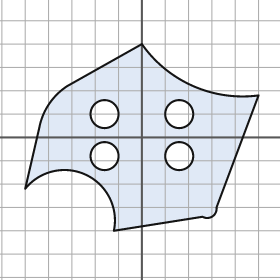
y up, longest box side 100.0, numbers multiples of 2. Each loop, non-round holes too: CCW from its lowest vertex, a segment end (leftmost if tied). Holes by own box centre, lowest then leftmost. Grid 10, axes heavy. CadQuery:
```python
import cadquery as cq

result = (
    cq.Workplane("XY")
    .moveTo(-12.0, -40.0)
    .lineTo(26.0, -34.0)
    .threePointArc((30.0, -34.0), (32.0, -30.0))
    .lineTo(50.0, 18.0)
    .threePointArc((22.0, 22.0), (0.0, 40.0))
    .lineTo(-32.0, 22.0)
    .threePointArc((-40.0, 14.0), (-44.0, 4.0))
    .lineTo(-50.0, -22.0)
    .threePointArc((-24.0, -16.0), (-12.0, -40.0))
    .close()
    .moveTo(-16.0, -8.0)
    .circle(6.0)
    .moveTo(16.0, -8.0)
    .circle(6.0)
    .moveTo(-16.0, 10.0)
    .circle(6.0)
    .moveTo(16.0, 10.0)
    .circle(6.0)
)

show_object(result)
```